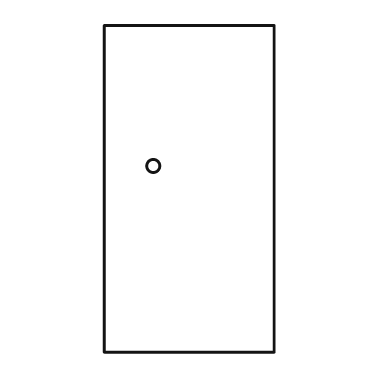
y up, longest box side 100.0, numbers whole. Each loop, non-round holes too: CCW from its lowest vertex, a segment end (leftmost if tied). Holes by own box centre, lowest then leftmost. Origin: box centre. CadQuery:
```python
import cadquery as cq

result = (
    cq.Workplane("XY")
    .moveTo(-26.0, -50.0)
    .lineTo(26.0, -50.0)
    .lineTo(26.0, 50.0)
    .lineTo(-26.0, 50.0)
    .close()
    .moveTo(-11.0, 7.0)
    .circle(2.0)
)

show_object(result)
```